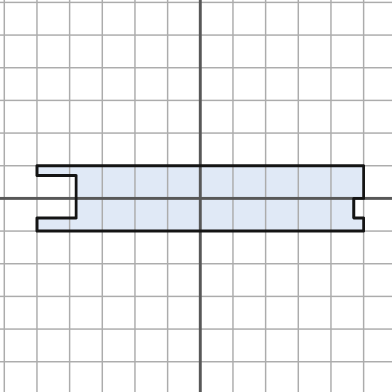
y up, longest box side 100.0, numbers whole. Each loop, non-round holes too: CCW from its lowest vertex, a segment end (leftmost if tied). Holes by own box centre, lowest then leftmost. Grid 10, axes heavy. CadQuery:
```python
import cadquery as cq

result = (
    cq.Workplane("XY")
    .moveTo(-50.0, -10.0)
    .lineTo(50.0, -10.0)
    .lineTo(50.0, -6.0)
    .lineTo(47.0, -6.0)
    .lineTo(47.0, 0.0)
    .lineTo(50.0, 0.0)
    .lineTo(50.0, 10.0)
    .lineTo(-50.0, 10.0)
    .lineTo(-50.0, 7.0)
    .lineTo(-38.0, 7.0)
    .lineTo(-38.0, -6.0)
    .lineTo(-50.0, -6.0)
    .close()
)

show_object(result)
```